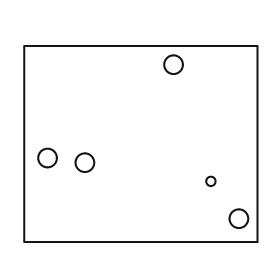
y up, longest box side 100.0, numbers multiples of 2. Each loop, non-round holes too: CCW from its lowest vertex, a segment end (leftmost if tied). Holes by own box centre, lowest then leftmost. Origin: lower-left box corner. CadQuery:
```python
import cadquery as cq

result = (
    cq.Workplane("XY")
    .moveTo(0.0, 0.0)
    .lineTo(100.0, 0.0)
    .lineTo(100.0, 84.0)
    .lineTo(0.0, 84.0)
    .close()
    .moveTo(92.0, 10.0)
    .circle(4.0)
    .moveTo(80.0, 26.0)
    .circle(2.0)
    .moveTo(26.0, 34.0)
    .circle(4.0)
    .moveTo(10.0, 36.0)
    .circle(4.0)
    .moveTo(64.0, 76.0)
    .circle(4.0)
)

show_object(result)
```